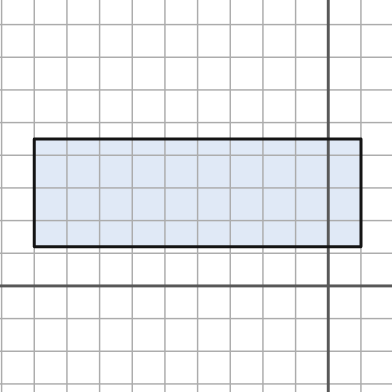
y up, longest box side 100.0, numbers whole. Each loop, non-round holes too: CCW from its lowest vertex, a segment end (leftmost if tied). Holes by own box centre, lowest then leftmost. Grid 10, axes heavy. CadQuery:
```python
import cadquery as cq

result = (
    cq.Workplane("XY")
    .moveTo(-90.0, 12.0)
    .lineTo(10.0, 12.0)
    .lineTo(10.0, 45.0)
    .lineTo(-90.0, 45.0)
    .close()
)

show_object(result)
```